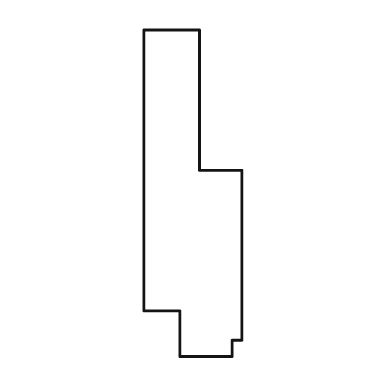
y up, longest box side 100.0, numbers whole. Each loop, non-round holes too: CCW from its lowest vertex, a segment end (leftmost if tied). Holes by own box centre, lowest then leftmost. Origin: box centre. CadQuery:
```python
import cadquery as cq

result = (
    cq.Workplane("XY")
    .moveTo(-4.0, -50.0)
    .lineTo(12.0, -50.0)
    .lineTo(12.0, -45.0)
    .lineTo(15.0, -45.0)
    .lineTo(15.0, 7.0)
    .lineTo(2.0, 7.0)
    .lineTo(2.0, 50.0)
    .lineTo(-15.0, 50.0)
    .lineTo(-15.0, -36.0)
    .lineTo(-4.0, -36.0)
    .close()
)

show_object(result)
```